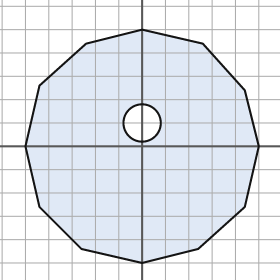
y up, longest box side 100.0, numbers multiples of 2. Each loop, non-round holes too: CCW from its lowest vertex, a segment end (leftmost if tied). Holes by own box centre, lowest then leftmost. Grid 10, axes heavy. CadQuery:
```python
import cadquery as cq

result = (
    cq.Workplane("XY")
    .moveTo(0.0, -50.0)
    .lineTo(24.0, -44.0)
    .lineTo(44.0, -26.0)
    .lineTo(50.0, 0.0)
    .lineTo(44.0, 24.0)
    .lineTo(26.0, 44.0)
    .lineTo(0.0, 50.0)
    .lineTo(-24.0, 44.0)
    .lineTo(-44.0, 26.0)
    .lineTo(-50.0, 0.0)
    .lineTo(-44.0, -26.0)
    .lineTo(-26.0, -44.0)
    .close()
    .moveTo(0.0, 10.0)
    .circle(8.0)
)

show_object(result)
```